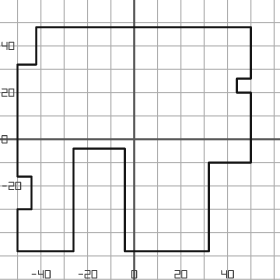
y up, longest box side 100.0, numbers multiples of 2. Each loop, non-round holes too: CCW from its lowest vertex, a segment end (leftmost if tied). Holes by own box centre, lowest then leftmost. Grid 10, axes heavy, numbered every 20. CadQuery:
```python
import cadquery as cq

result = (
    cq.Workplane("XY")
    .moveTo(-50.0, -48.0)
    .lineTo(-26.0, -48.0)
    .lineTo(-26.0, -4.0)
    .lineTo(-4.0, -4.0)
    .lineTo(-4.0, -48.0)
    .lineTo(32.0, -48.0)
    .lineTo(32.0, -10.0)
    .lineTo(50.0, -10.0)
    .lineTo(50.0, 20.0)
    .lineTo(44.0, 20.0)
    .lineTo(44.0, 26.0)
    .lineTo(50.0, 26.0)
    .lineTo(50.0, 48.0)
    .lineTo(-42.0, 48.0)
    .lineTo(-42.0, 32.0)
    .lineTo(-50.0, 32.0)
    .lineTo(-50.0, -16.0)
    .lineTo(-44.0, -16.0)
    .lineTo(-44.0, -30.0)
    .lineTo(-50.0, -30.0)
    .close()
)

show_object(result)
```